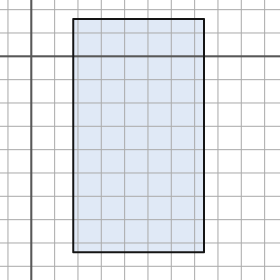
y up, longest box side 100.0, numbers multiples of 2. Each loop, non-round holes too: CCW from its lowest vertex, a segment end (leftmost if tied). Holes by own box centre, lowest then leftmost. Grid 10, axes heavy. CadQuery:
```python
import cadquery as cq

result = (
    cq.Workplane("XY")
    .moveTo(18.0, -84.0)
    .lineTo(74.0, -84.0)
    .lineTo(74.0, 16.0)
    .lineTo(18.0, 16.0)
    .close()
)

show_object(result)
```